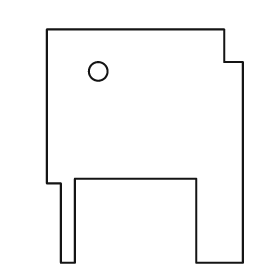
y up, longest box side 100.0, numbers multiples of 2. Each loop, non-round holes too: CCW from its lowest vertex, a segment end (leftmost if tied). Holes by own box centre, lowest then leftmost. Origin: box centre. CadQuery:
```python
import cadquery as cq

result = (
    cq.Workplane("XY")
    .moveTo(-36.0, -50.0)
    .lineTo(-30.0, -50.0)
    .lineTo(-30.0, -14.0)
    .lineTo(22.0, -14.0)
    .lineTo(22.0, -50.0)
    .lineTo(42.0, -50.0)
    .lineTo(42.0, 36.0)
    .lineTo(34.0, 36.0)
    .lineTo(34.0, 50.0)
    .lineTo(-42.0, 50.0)
    .lineTo(-42.0, -16.0)
    .lineTo(-36.0, -16.0)
    .close()
    .moveTo(-20.0, 32.0)
    .circle(4.0)
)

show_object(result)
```